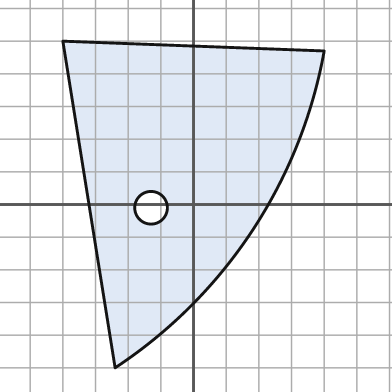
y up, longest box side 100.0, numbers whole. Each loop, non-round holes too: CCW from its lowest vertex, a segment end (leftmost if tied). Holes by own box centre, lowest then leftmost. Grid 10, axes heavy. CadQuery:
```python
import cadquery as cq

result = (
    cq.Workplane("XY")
    .moveTo(-24.0, -50.0)
    .threePointArc((18.0, -8.0), (40.0, 47.0))
    .lineTo(-40.0, 50.0)
    .close()
    .moveTo(-13.0, -1.0)
    .circle(5.0)
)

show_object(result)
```